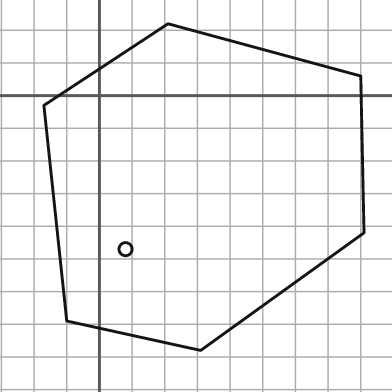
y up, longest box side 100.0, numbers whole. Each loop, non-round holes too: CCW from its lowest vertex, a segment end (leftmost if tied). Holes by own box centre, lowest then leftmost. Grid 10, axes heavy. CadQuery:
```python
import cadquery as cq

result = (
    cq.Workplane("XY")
    .moveTo(31.0, -78.0)
    .lineTo(81.0, -42.0)
    .lineTo(80.0, 6.0)
    .lineTo(21.0, 22.0)
    .lineTo(-17.0, -3.0)
    .lineTo(-10.0, -69.0)
    .close()
    .moveTo(8.0, -47.0)
    .circle(2.0)
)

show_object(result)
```